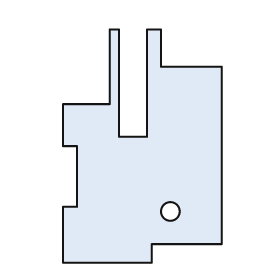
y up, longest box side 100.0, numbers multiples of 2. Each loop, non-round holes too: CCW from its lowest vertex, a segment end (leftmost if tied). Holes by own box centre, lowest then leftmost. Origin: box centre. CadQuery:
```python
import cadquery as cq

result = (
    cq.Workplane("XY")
    .moveTo(-34.0, -50.0)
    .lineTo(4.0, -50.0)
    .lineTo(4.0, -42.0)
    .lineTo(34.0, -42.0)
    .lineTo(34.0, 34.0)
    .lineTo(8.0, 34.0)
    .lineTo(8.0, 50.0)
    .lineTo(2.0, 50.0)
    .lineTo(2.0, 4.0)
    .lineTo(-10.0, 4.0)
    .lineTo(-10.0, 50.0)
    .lineTo(-14.0, 50.0)
    .lineTo(-14.0, 18.0)
    .lineTo(-34.0, 18.0)
    .lineTo(-34.0, 0.0)
    .lineTo(-28.0, 0.0)
    .lineTo(-28.0, -26.0)
    .lineTo(-34.0, -26.0)
    .close()
    .moveTo(12.0, -28.0)
    .circle(4.0)
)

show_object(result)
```